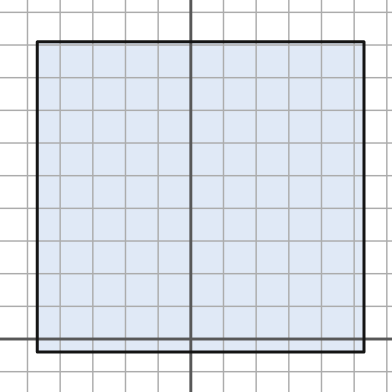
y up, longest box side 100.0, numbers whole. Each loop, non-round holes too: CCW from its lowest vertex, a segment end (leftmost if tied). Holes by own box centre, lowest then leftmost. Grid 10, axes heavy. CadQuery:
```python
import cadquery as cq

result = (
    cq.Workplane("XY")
    .moveTo(-47.0, -4.0)
    .lineTo(53.0, -4.0)
    .lineTo(53.0, 91.0)
    .lineTo(-47.0, 91.0)
    .close()
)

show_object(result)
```